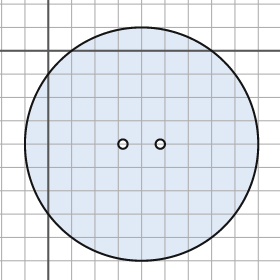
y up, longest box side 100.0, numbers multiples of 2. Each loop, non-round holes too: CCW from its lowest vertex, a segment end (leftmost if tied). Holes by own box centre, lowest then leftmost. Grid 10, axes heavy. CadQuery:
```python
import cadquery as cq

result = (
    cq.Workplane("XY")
    .moveTo(40.0, -40.0)
    .circle(50.0)
    .moveTo(32.0, -40.0)
    .circle(2.0)
    .moveTo(48.0, -40.0)
    .circle(2.0)
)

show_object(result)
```